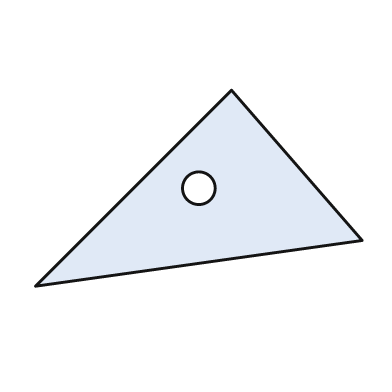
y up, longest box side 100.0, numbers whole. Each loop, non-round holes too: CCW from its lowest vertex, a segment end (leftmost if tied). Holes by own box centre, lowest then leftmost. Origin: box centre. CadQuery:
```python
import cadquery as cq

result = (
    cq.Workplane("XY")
    .moveTo(-50.0, -30.0)
    .lineTo(50.0, -16.0)
    .lineTo(10.0, 30.0)
    .close()
    .moveTo(0.0, 0.0)
    .circle(5.0)
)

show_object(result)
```